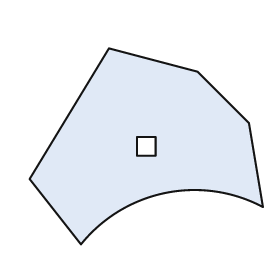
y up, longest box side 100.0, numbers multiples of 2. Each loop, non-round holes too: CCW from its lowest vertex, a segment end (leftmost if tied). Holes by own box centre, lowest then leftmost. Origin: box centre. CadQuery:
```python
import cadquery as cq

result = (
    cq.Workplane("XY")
    .moveTo(-28.0, -42.0)
    .threePointArc((8.0, -20.0), (50.0, -26.0))
    .lineTo(44.0, 10.0)
    .lineTo(22.0, 32.0)
    .lineTo(-16.0, 42.0)
    .lineTo(-50.0, -14.0)
    .close()
    .moveTo(-4.0, -4.0)
    .lineTo(4.0, -4.0)
    .lineTo(4.0, 4.0)
    .lineTo(-4.0, 4.0)
    .close()
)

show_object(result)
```